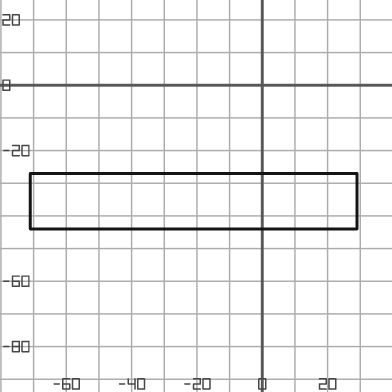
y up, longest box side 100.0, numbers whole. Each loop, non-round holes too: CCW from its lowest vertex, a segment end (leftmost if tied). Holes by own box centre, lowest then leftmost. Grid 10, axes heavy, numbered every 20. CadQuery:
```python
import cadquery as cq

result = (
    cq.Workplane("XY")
    .moveTo(-71.0, -44.0)
    .lineTo(29.0, -44.0)
    .lineTo(29.0, -27.0)
    .lineTo(-71.0, -27.0)
    .close()
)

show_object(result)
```